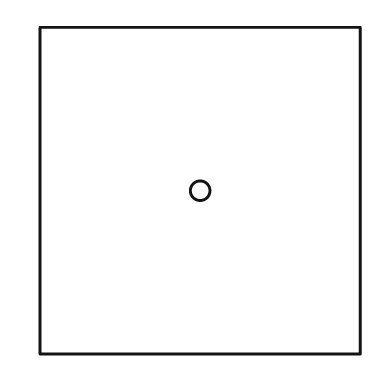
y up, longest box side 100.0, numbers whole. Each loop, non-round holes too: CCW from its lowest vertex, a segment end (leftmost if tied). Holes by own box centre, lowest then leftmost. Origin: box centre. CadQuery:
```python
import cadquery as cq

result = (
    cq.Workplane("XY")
    .moveTo(-49.0, -50.0)
    .lineTo(49.0, -50.0)
    .lineTo(49.0, 50.0)
    .lineTo(-49.0, 50.0)
    .close()
    .moveTo(0.0, 0.0)
    .circle(3.0)
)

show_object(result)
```